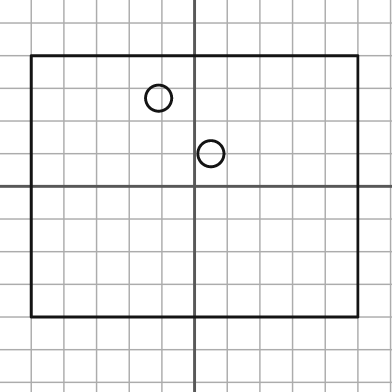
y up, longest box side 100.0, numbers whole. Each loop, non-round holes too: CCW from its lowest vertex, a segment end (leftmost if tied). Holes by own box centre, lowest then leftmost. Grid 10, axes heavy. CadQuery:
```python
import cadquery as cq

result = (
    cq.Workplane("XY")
    .moveTo(-50.0, -40.0)
    .lineTo(50.0, -40.0)
    .lineTo(50.0, 40.0)
    .lineTo(-50.0, 40.0)
    .close()
    .moveTo(5.0, 10.0)
    .circle(4.0)
    .moveTo(-11.0, 27.0)
    .circle(4.0)
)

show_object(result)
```